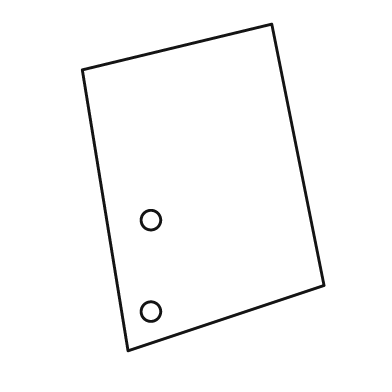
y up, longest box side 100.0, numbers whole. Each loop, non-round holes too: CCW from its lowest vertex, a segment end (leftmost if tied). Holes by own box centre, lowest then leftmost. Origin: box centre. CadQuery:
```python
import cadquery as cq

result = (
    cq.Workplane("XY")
    .moveTo(-23.0, -50.0)
    .lineTo(37.0, -30.0)
    .lineTo(21.0, 50.0)
    .lineTo(-37.0, 36.0)
    .close()
    .moveTo(-16.0, -38.0)
    .circle(3.0)
    .moveTo(-16.0, -10.0)
    .circle(3.0)
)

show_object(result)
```